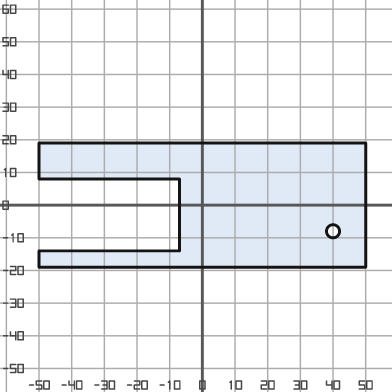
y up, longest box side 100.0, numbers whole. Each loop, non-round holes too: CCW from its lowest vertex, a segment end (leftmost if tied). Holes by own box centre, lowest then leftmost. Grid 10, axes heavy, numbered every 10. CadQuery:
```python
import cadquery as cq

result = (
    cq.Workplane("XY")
    .moveTo(-50.0, -19.0)
    .lineTo(50.0, -19.0)
    .lineTo(50.0, 19.0)
    .lineTo(-50.0, 19.0)
    .lineTo(-50.0, 8.0)
    .lineTo(-7.0, 8.0)
    .lineTo(-7.0, -14.0)
    .lineTo(-50.0, -14.0)
    .close()
    .moveTo(40.0, -8.0)
    .circle(2.0)
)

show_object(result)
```